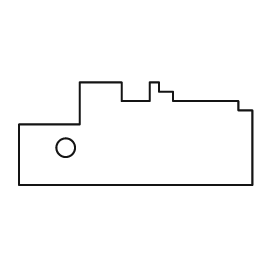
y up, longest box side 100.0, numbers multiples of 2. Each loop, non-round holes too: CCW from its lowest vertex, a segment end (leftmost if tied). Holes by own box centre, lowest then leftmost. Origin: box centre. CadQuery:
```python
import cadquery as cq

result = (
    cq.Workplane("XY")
    .moveTo(-50.0, -22.0)
    .lineTo(50.0, -22.0)
    .lineTo(50.0, 10.0)
    .lineTo(44.0, 10.0)
    .lineTo(44.0, 14.0)
    .lineTo(16.0, 14.0)
    .lineTo(16.0, 18.0)
    .lineTo(10.0, 18.0)
    .lineTo(10.0, 22.0)
    .lineTo(6.0, 22.0)
    .lineTo(6.0, 14.0)
    .lineTo(-6.0, 14.0)
    .lineTo(-6.0, 22.0)
    .lineTo(-24.0, 22.0)
    .lineTo(-24.0, 4.0)
    .lineTo(-50.0, 4.0)
    .close()
    .moveTo(-30.0, -6.0)
    .circle(4.0)
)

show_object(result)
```